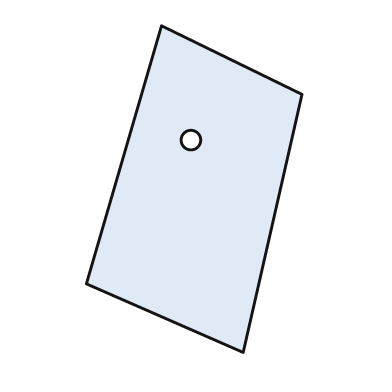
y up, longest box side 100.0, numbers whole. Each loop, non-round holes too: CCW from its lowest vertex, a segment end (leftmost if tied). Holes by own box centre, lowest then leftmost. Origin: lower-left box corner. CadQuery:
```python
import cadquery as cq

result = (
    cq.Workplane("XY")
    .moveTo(48.0, 0.0)
    .lineTo(66.0, 79.0)
    .lineTo(23.0, 100.0)
    .lineTo(0.0, 21.0)
    .close()
    .moveTo(32.0, 65.0)
    .circle(3.0)
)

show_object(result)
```